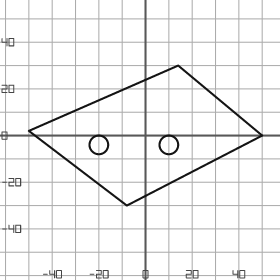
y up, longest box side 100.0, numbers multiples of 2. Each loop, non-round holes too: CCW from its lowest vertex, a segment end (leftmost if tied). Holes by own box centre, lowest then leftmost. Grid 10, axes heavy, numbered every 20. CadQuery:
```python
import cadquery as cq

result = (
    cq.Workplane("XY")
    .moveTo(-8.0, -30.0)
    .lineTo(50.0, 0.0)
    .lineTo(14.0, 30.0)
    .lineTo(-50.0, 2.0)
    .close()
    .moveTo(-20.0, -4.0)
    .circle(4.0)
    .moveTo(10.0, -4.0)
    .circle(4.0)
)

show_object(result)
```